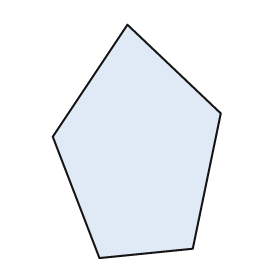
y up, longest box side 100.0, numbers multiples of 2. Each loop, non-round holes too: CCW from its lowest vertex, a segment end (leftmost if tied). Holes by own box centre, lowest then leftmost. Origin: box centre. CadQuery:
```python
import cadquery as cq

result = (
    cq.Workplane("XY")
    .moveTo(-16.0, -50.0)
    .lineTo(24.0, -46.0)
    .lineTo(36.0, 12.0)
    .lineTo(-4.0, 50.0)
    .lineTo(-36.0, 2.0)
    .close()
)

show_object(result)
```